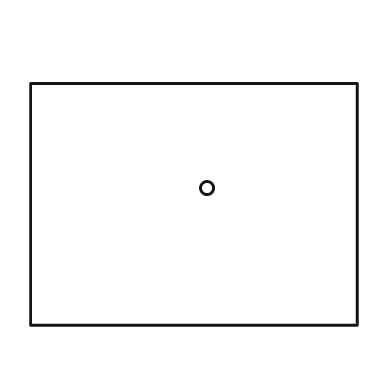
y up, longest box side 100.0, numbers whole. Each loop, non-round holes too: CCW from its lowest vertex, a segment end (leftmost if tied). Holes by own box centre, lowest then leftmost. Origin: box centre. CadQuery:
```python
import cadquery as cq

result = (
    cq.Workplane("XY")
    .moveTo(-50.0, -37.0)
    .lineTo(50.0, -37.0)
    .lineTo(50.0, 37.0)
    .lineTo(-50.0, 37.0)
    .close()
    .moveTo(4.0, 5.0)
    .circle(2.0)
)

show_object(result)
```